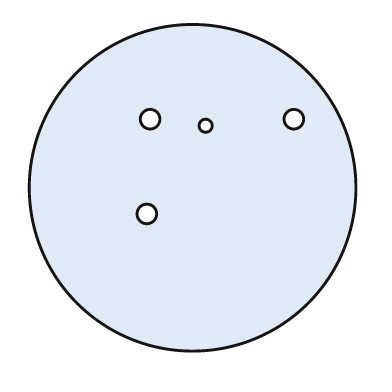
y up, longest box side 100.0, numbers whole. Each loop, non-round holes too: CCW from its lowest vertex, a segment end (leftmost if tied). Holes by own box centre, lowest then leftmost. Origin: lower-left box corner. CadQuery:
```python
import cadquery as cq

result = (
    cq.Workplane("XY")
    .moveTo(50.0, 50.0)
    .circle(50.0)
    .moveTo(36.0, 42.0)
    .circle(3.0)
    .moveTo(54.0, 69.0)
    .circle(2.0)
    .moveTo(37.0, 71.0)
    .circle(3.0)
    .moveTo(81.0, 71.0)
    .circle(3.0)
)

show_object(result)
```